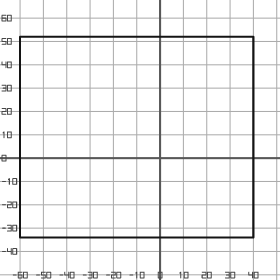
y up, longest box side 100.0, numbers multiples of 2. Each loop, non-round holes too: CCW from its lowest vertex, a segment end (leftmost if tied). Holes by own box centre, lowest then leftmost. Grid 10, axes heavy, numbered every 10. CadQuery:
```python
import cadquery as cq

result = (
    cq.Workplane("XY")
    .moveTo(-60.0, -34.0)
    .lineTo(40.0, -34.0)
    .lineTo(40.0, 52.0)
    .lineTo(-60.0, 52.0)
    .close()
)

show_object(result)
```